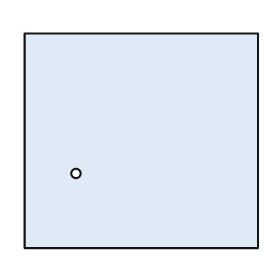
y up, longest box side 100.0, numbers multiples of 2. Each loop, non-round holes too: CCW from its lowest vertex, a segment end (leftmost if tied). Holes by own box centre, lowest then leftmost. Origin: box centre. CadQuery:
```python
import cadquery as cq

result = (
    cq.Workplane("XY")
    .moveTo(-50.0, -46.0)
    .lineTo(50.0, -46.0)
    .lineTo(50.0, 46.0)
    .lineTo(-50.0, 46.0)
    .close()
    .moveTo(-28.0, -14.0)
    .circle(2.0)
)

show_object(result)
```